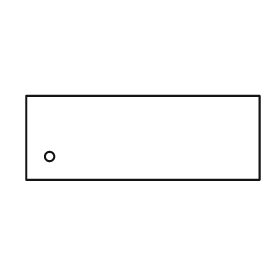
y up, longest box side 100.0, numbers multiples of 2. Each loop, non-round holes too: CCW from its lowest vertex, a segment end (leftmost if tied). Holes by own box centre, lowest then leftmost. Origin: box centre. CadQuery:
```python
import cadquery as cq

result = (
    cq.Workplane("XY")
    .moveTo(-50.0, -18.0)
    .lineTo(50.0, -18.0)
    .lineTo(50.0, 18.0)
    .lineTo(-50.0, 18.0)
    .close()
    .moveTo(-40.0, -8.0)
    .circle(2.0)
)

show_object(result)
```